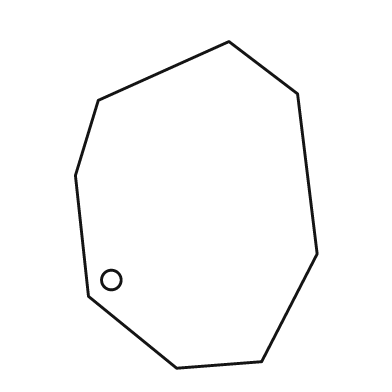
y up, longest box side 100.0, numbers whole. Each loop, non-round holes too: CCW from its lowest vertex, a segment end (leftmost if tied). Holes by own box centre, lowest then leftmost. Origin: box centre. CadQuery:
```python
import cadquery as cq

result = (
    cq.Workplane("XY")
    .moveTo(-6.0, -50.0)
    .lineTo(20.0, -48.0)
    .lineTo(37.0, -15.0)
    .lineTo(31.0, 34.0)
    .lineTo(10.0, 50.0)
    .lineTo(-30.0, 32.0)
    .lineTo(-37.0, 9.0)
    .lineTo(-33.0, -28.0)
    .close()
    .moveTo(-26.0, -23.0)
    .circle(3.0)
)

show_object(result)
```